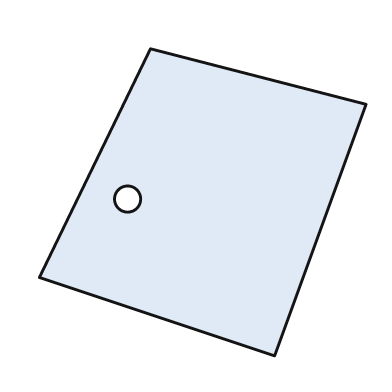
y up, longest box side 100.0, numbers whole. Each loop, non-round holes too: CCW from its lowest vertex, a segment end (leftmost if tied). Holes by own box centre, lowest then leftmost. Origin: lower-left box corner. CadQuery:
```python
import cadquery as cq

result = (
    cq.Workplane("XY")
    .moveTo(72.0, 0.0)
    .lineTo(100.0, 77.0)
    .lineTo(34.0, 94.0)
    .lineTo(0.0, 24.0)
    .close()
    .moveTo(27.0, 48.0)
    .circle(4.0)
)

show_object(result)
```